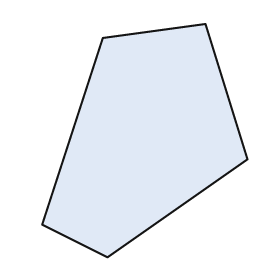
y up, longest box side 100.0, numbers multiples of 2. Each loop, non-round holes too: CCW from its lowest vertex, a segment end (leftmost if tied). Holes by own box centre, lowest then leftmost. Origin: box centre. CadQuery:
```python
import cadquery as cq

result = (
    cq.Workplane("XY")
    .moveTo(-16.0, -50.0)
    .lineTo(44.0, -8.0)
    .lineTo(26.0, 50.0)
    .lineTo(-18.0, 44.0)
    .lineTo(-44.0, -36.0)
    .close()
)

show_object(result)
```